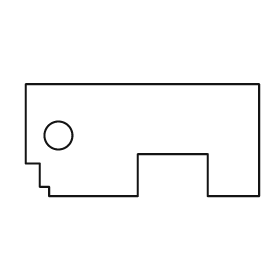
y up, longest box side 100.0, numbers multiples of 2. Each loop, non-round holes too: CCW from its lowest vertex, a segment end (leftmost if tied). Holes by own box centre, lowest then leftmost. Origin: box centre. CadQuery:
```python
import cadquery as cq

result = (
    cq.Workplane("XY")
    .moveTo(-40.0, -24.0)
    .lineTo(-2.0, -24.0)
    .lineTo(-2.0, -6.0)
    .lineTo(28.0, -6.0)
    .lineTo(28.0, -24.0)
    .lineTo(50.0, -24.0)
    .lineTo(50.0, 24.0)
    .lineTo(-50.0, 24.0)
    .lineTo(-50.0, -10.0)
    .lineTo(-44.0, -10.0)
    .lineTo(-44.0, -20.0)
    .lineTo(-40.0, -20.0)
    .close()
    .moveTo(-36.0, 2.0)
    .circle(6.0)
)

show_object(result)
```